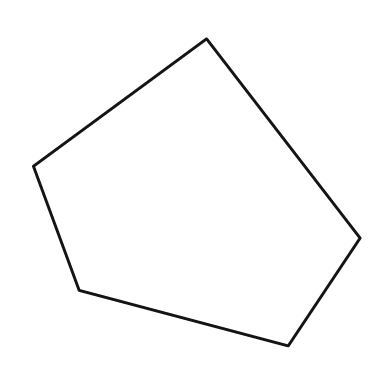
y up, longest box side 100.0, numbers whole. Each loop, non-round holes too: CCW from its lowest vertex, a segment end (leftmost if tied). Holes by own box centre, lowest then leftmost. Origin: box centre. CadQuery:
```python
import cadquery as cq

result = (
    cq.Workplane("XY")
    .moveTo(28.0, -47.0)
    .lineTo(50.0, -14.0)
    .lineTo(3.0, 47.0)
    .lineTo(-50.0, 8.0)
    .lineTo(-36.0, -30.0)
    .close()
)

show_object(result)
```